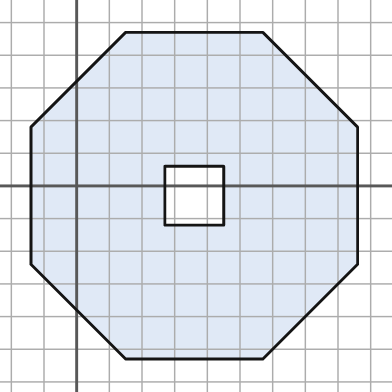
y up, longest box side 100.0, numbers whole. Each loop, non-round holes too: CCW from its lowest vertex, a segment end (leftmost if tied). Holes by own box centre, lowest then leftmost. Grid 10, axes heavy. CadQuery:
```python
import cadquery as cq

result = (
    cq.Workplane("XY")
    .moveTo(15.0, -53.0)
    .lineTo(57.0, -53.0)
    .lineTo(86.0, -24.0)
    .lineTo(86.0, 18.0)
    .lineTo(57.0, 47.0)
    .lineTo(15.0, 47.0)
    .lineTo(-14.0, 18.0)
    .lineTo(-14.0, -24.0)
    .close()
    .moveTo(27.0, -12.0)
    .lineTo(45.0, -12.0)
    .lineTo(45.0, 6.0)
    .lineTo(27.0, 6.0)
    .close()
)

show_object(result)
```